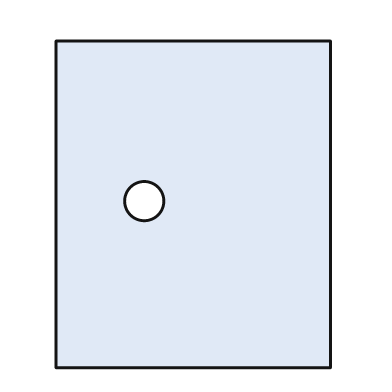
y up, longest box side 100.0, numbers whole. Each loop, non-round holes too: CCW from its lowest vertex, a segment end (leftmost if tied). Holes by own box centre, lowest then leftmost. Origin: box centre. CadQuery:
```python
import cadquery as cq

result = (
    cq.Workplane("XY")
    .moveTo(-42.0, -50.0)
    .lineTo(42.0, -50.0)
    .lineTo(42.0, 50.0)
    .lineTo(-42.0, 50.0)
    .close()
    .moveTo(-15.0, 1.0)
    .circle(6.0)
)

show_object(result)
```